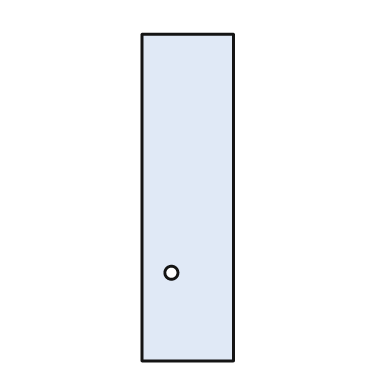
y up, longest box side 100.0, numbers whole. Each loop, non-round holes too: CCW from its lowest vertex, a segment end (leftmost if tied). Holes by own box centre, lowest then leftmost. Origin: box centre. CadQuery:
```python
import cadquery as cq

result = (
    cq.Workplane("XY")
    .moveTo(-14.0, -50.0)
    .lineTo(14.0, -50.0)
    .lineTo(14.0, 50.0)
    .lineTo(-14.0, 50.0)
    .close()
    .moveTo(-5.0, -23.0)
    .circle(2.0)
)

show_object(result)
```